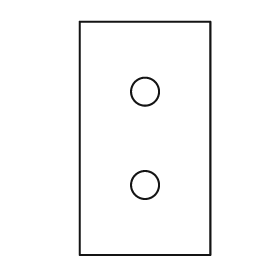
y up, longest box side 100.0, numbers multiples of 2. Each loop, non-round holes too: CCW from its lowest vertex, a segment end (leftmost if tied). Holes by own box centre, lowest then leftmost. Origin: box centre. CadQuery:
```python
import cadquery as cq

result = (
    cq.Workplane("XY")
    .moveTo(-28.0, -50.0)
    .lineTo(28.0, -50.0)
    .lineTo(28.0, 50.0)
    .lineTo(-28.0, 50.0)
    .close()
    .moveTo(0.0, -20.0)
    .circle(6.0)
    .moveTo(0.0, 20.0)
    .circle(6.0)
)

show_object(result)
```